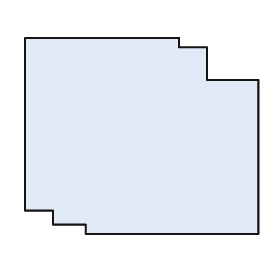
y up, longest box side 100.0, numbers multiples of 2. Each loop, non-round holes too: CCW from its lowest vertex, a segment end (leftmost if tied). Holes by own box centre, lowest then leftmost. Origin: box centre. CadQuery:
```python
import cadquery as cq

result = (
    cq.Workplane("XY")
    .moveTo(-24.0, -42.0)
    .lineTo(50.0, -42.0)
    .lineTo(50.0, 24.0)
    .lineTo(28.0, 24.0)
    .lineTo(28.0, 38.0)
    .lineTo(16.0, 38.0)
    .lineTo(16.0, 42.0)
    .lineTo(-50.0, 42.0)
    .lineTo(-50.0, -32.0)
    .lineTo(-38.0, -32.0)
    .lineTo(-38.0, -38.0)
    .lineTo(-24.0, -38.0)
    .close()
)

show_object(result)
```